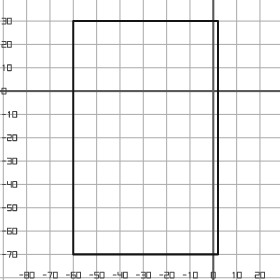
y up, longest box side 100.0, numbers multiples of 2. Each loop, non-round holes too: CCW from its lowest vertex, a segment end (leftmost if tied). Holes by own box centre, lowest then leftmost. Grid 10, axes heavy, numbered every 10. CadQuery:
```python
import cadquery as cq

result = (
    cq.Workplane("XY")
    .moveTo(-60.0, -70.0)
    .lineTo(2.0, -70.0)
    .lineTo(2.0, 30.0)
    .lineTo(-60.0, 30.0)
    .close()
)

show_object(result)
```